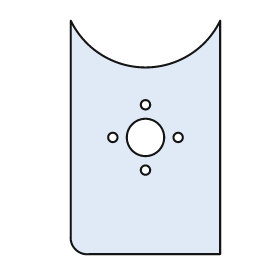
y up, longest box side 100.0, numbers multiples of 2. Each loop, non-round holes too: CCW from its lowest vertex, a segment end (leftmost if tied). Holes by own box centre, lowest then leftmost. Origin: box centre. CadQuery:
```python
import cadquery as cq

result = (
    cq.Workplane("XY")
    .moveTo(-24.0, -50.0)
    .lineTo(32.0, -50.0)
    .lineTo(32.0, 50.0)
    .threePointArc((0.0, 30.0), (-32.0, 50.0))
    .lineTo(-32.0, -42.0)
    .threePointArc((-30.0, -48.0), (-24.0, -50.0))
    .close()
    .moveTo(0.0, -14.0)
    .circle(2.0)
    .moveTo(-14.0, 0.0)
    .circle(2.0)
    .moveTo(0.0, 0.0)
    .circle(8.0)
    .moveTo(14.0, 0.0)
    .circle(2.0)
    .moveTo(0.0, 14.0)
    .circle(2.0)
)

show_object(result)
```